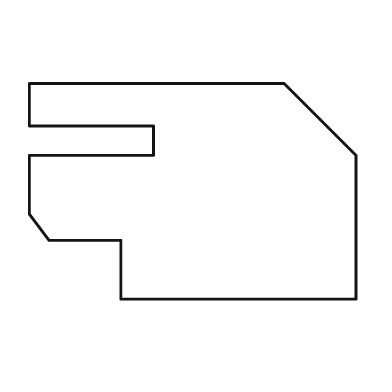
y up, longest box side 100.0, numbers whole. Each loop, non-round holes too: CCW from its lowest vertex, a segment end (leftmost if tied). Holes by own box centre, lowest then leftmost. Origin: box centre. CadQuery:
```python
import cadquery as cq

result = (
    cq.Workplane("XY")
    .moveTo(-22.0, -33.0)
    .lineTo(50.0, -33.0)
    .lineTo(50.0, 11.0)
    .lineTo(28.0, 33.0)
    .lineTo(-50.0, 33.0)
    .lineTo(-50.0, 20.0)
    .lineTo(-12.0, 20.0)
    .lineTo(-12.0, 11.0)
    .lineTo(-50.0, 11.0)
    .lineTo(-50.0, -7.0)
    .lineTo(-44.0, -15.0)
    .lineTo(-22.0, -15.0)
    .close()
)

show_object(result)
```